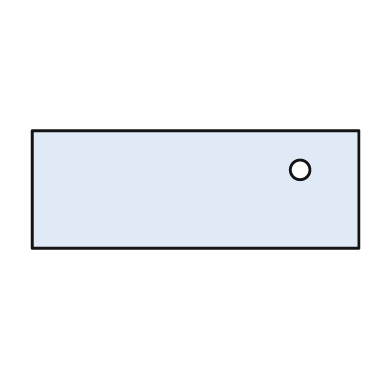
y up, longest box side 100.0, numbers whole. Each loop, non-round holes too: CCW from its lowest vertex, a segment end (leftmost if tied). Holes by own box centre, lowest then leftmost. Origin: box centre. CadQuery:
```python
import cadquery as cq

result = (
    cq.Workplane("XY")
    .moveTo(-50.0, -18.0)
    .lineTo(50.0, -18.0)
    .lineTo(50.0, 18.0)
    .lineTo(-50.0, 18.0)
    .close()
    .moveTo(32.0, 6.0)
    .circle(3.0)
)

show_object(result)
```